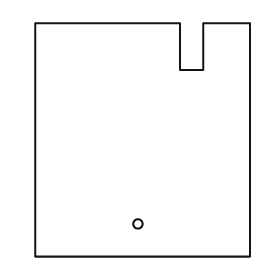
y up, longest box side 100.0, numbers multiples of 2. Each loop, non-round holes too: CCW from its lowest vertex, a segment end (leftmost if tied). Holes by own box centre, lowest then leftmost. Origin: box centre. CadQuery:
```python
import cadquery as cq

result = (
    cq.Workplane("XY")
    .moveTo(-46.0, -50.0)
    .lineTo(46.0, -50.0)
    .lineTo(46.0, 50.0)
    .lineTo(26.0, 50.0)
    .lineTo(26.0, 30.0)
    .lineTo(16.0, 30.0)
    .lineTo(16.0, 50.0)
    .lineTo(-46.0, 50.0)
    .close()
    .moveTo(-2.0, -36.0)
    .circle(2.0)
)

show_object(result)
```